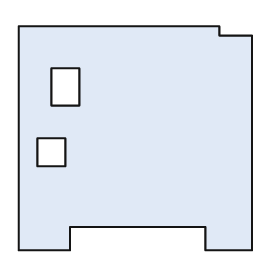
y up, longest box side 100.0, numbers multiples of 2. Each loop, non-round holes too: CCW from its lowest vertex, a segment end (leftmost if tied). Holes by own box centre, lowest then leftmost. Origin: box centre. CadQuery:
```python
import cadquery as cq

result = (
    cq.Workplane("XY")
    .moveTo(-50.0, -48.0)
    .lineTo(-28.0, -48.0)
    .lineTo(-28.0, -38.0)
    .lineTo(30.0, -38.0)
    .lineTo(30.0, -48.0)
    .lineTo(50.0, -48.0)
    .lineTo(50.0, 44.0)
    .lineTo(36.0, 44.0)
    .lineTo(36.0, 48.0)
    .lineTo(-50.0, 48.0)
    .close()
    .moveTo(-42.0, -12.0)
    .lineTo(-30.0, -12.0)
    .lineTo(-30.0, 0.0)
    .lineTo(-42.0, 0.0)
    .close()
    .moveTo(-36.0, 14.0)
    .lineTo(-24.0, 14.0)
    .lineTo(-24.0, 30.0)
    .lineTo(-36.0, 30.0)
    .close()
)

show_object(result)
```